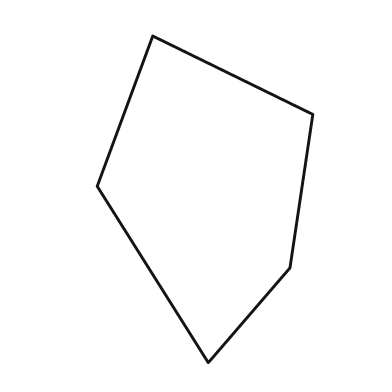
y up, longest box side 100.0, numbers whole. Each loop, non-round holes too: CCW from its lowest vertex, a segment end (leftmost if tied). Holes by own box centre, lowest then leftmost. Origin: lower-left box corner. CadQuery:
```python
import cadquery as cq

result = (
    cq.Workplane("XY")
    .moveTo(34.0, 0.0)
    .lineTo(59.0, 29.0)
    .lineTo(66.0, 76.0)
    .lineTo(17.0, 100.0)
    .lineTo(0.0, 54.0)
    .close()
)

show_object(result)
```